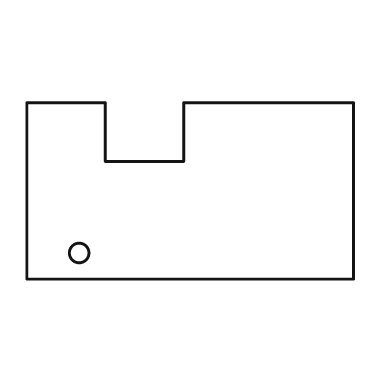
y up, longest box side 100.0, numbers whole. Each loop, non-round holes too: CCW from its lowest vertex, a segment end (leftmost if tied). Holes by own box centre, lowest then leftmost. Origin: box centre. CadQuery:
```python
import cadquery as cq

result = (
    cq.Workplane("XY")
    .moveTo(-50.0, -27.0)
    .lineTo(50.0, -27.0)
    .lineTo(50.0, 27.0)
    .lineTo(-2.0, 27.0)
    .lineTo(-2.0, 9.0)
    .lineTo(-26.0, 9.0)
    .lineTo(-26.0, 27.0)
    .lineTo(-50.0, 27.0)
    .close()
    .moveTo(-34.0, -19.0)
    .circle(3.0)
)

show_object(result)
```